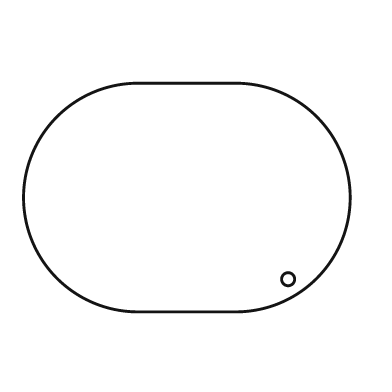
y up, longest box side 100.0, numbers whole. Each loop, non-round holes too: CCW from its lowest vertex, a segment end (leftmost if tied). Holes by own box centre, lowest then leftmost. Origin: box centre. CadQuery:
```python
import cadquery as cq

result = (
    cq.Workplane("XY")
    .moveTo(-15.0, -35.0)
    .lineTo(15.0, -35.0)
    .threePointArc((50.0, 0.0), (15.0, 35.0))
    .lineTo(-15.0, 35.0)
    .threePointArc((-50.0, 0.0), (-15.0, -35.0))
    .close()
    .moveTo(31.0, -25.0)
    .circle(2.0)
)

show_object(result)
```